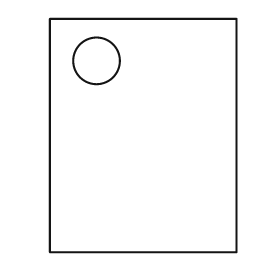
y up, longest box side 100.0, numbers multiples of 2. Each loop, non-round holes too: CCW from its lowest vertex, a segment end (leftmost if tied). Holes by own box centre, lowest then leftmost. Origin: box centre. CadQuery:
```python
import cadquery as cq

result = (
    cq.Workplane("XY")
    .moveTo(-40.0, -50.0)
    .lineTo(40.0, -50.0)
    .lineTo(40.0, 50.0)
    .lineTo(-40.0, 50.0)
    .close()
    .moveTo(-20.0, 32.0)
    .circle(10.0)
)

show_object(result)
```